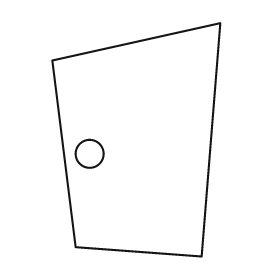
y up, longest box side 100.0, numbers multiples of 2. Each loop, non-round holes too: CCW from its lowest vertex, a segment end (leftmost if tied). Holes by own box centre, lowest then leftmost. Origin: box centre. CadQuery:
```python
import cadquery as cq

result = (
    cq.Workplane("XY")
    .moveTo(28.0, -50.0)
    .lineTo(36.0, 50.0)
    .lineTo(-36.0, 34.0)
    .lineTo(-26.0, -46.0)
    .close()
    .moveTo(-20.0, -6.0)
    .circle(6.0)
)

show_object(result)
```